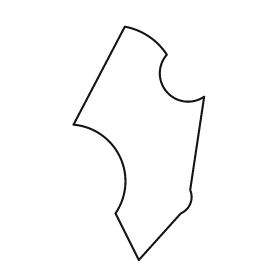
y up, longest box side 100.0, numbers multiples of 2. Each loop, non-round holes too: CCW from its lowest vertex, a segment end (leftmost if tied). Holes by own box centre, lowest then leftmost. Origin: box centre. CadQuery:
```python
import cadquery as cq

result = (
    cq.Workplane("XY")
    .moveTo(0.0, -50.0)
    .lineTo(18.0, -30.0)
    .threePointArc((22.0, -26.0), (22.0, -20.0))
    .lineTo(28.0, 20.0)
    .threePointArc((12.0, 22.0), (12.0, 38.0))
    .threePointArc((4.0, 46.0), (-6.0, 50.0))
    .lineTo(-28.0, 8.0)
    .threePointArc((-8.0, -6.0), (-10.0, -30.0))
    .close()
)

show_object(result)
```